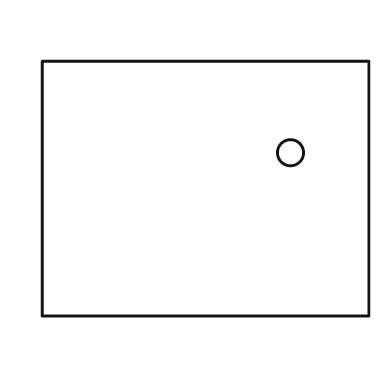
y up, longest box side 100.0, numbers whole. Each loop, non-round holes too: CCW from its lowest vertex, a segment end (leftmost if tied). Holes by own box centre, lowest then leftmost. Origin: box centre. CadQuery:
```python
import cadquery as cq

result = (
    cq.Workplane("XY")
    .moveTo(-50.0, -39.0)
    .lineTo(50.0, -39.0)
    .lineTo(50.0, 39.0)
    .lineTo(-50.0, 39.0)
    .close()
    .moveTo(26.0, 11.0)
    .circle(4.0)
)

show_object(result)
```